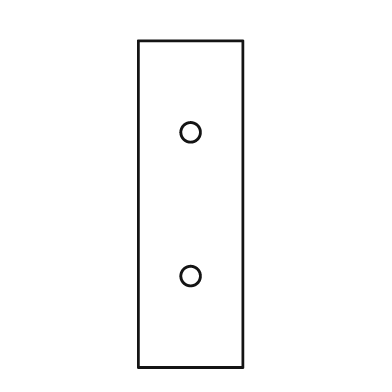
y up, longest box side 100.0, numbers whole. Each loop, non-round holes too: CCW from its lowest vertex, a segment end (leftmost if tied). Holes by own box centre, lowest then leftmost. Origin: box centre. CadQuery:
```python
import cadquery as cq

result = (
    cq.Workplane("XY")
    .moveTo(-16.0, -50.0)
    .lineTo(16.0, -50.0)
    .lineTo(16.0, 50.0)
    .lineTo(-16.0, 50.0)
    .close()
    .moveTo(0.0, -22.0)
    .circle(3.0)
    .moveTo(0.0, 22.0)
    .circle(3.0)
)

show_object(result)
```